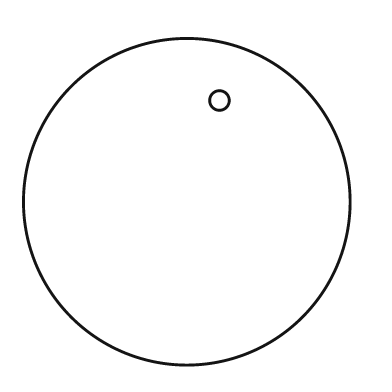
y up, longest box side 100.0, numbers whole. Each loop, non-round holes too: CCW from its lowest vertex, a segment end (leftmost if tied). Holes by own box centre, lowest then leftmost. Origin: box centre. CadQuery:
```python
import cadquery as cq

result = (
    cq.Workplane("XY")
    .moveTo(0.0, 0.0)
    .circle(50.0)
    .moveTo(10.0, 31.0)
    .circle(3.0)
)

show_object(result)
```